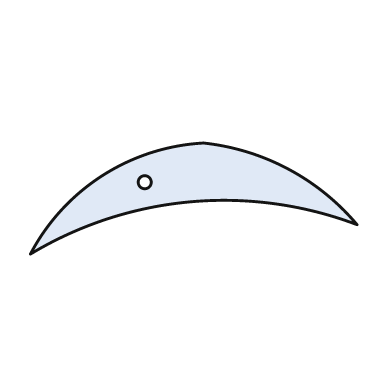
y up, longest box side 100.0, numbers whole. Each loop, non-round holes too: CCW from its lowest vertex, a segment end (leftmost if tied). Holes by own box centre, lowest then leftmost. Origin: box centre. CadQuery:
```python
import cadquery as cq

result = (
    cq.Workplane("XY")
    .moveTo(-50.0, -17.0)
    .threePointArc((-1.0, -1.0), (50.0, -8.0))
    .threePointArc((29.0, 9.0), (3.0, 17.0))
    .threePointArc((-28.0, 7.0), (-50.0, -17.0))
    .close()
    .moveTo(-15.0, 5.0)
    .circle(2.0)
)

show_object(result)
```